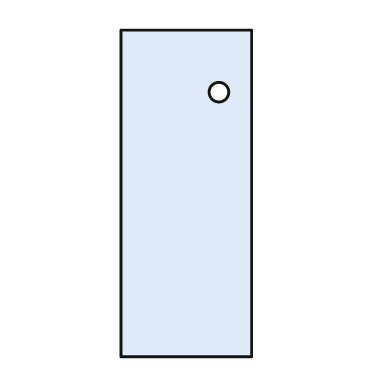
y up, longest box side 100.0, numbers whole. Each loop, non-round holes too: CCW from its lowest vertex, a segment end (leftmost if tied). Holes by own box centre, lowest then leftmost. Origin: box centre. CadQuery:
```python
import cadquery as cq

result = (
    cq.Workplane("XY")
    .moveTo(-20.0, -50.0)
    .lineTo(20.0, -50.0)
    .lineTo(20.0, 50.0)
    .lineTo(-20.0, 50.0)
    .close()
    .moveTo(10.0, 31.0)
    .circle(3.0)
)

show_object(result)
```